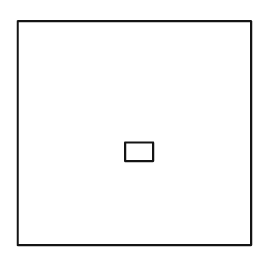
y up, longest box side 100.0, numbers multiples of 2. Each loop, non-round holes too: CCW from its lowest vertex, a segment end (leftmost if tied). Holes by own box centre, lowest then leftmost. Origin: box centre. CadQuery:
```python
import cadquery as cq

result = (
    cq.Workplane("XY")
    .moveTo(-50.0, -48.0)
    .lineTo(50.0, -48.0)
    .lineTo(50.0, 48.0)
    .lineTo(-50.0, 48.0)
    .close()
    .moveTo(-4.0, -12.0)
    .lineTo(8.0, -12.0)
    .lineTo(8.0, -4.0)
    .lineTo(-4.0, -4.0)
    .close()
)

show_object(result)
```